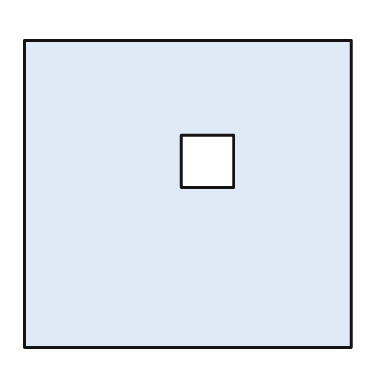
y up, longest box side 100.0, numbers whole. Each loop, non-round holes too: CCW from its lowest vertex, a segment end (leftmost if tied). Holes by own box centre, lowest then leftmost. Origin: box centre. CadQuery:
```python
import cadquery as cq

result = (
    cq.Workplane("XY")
    .moveTo(-50.0, -47.0)
    .lineTo(50.0, -47.0)
    .lineTo(50.0, 47.0)
    .lineTo(-50.0, 47.0)
    .close()
    .moveTo(-2.0, 2.0)
    .lineTo(14.0, 2.0)
    .lineTo(14.0, 18.0)
    .lineTo(-2.0, 18.0)
    .close()
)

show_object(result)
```